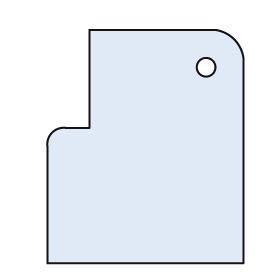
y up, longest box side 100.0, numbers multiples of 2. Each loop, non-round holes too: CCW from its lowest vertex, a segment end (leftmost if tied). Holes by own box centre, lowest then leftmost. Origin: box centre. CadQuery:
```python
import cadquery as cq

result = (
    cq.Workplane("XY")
    .moveTo(-42.0, -50.0)
    .lineTo(42.0, -50.0)
    .lineTo(42.0, 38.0)
    .threePointArc((38.0, 46.0), (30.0, 50.0))
    .lineTo(-24.0, 50.0)
    .lineTo(-24.0, 8.0)
    .lineTo(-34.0, 8.0)
    .threePointArc((-40.0, 6.0), (-42.0, 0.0))
    .close()
    .moveTo(26.0, 34.0)
    .circle(4.0)
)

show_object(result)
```